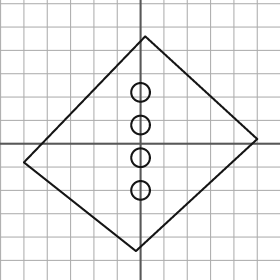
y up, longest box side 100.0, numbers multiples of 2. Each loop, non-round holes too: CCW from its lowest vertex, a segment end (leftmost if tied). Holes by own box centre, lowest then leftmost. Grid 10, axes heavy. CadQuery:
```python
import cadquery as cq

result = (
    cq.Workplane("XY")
    .moveTo(-2.0, -46.0)
    .lineTo(50.0, 2.0)
    .lineTo(2.0, 46.0)
    .lineTo(-50.0, -8.0)
    .close()
    .moveTo(0.0, -20.0)
    .circle(4.0)
    .moveTo(0.0, -6.0)
    .circle(4.0)
    .moveTo(0.0, 8.0)
    .circle(4.0)
    .moveTo(0.0, 22.0)
    .circle(4.0)
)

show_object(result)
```